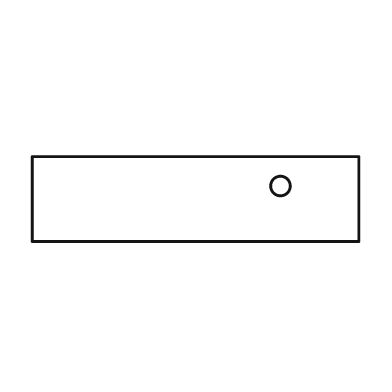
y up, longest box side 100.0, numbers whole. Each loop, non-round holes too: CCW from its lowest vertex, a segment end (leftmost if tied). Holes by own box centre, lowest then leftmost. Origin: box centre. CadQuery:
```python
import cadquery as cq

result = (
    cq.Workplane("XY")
    .moveTo(-50.0, -13.0)
    .lineTo(50.0, -13.0)
    .lineTo(50.0, 13.0)
    .lineTo(-50.0, 13.0)
    .close()
    .moveTo(26.0, 4.0)
    .circle(3.0)
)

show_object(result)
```